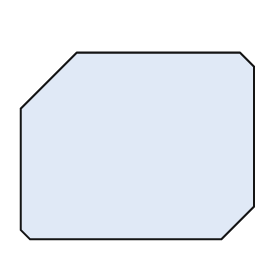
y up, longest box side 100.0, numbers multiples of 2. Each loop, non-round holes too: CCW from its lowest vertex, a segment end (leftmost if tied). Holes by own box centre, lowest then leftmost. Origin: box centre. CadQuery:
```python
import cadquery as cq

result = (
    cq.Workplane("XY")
    .moveTo(-46.0, -40.0)
    .lineTo(36.0, -40.0)
    .lineTo(50.0, -26.0)
    .lineTo(50.0, 34.0)
    .lineTo(44.0, 40.0)
    .lineTo(-26.0, 40.0)
    .lineTo(-50.0, 16.0)
    .lineTo(-50.0, -36.0)
    .close()
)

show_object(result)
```